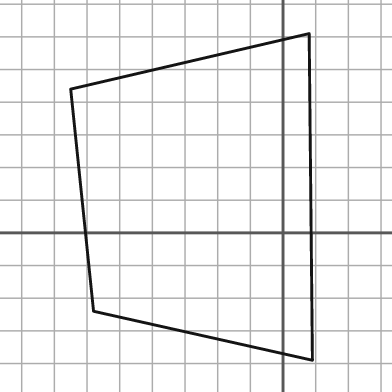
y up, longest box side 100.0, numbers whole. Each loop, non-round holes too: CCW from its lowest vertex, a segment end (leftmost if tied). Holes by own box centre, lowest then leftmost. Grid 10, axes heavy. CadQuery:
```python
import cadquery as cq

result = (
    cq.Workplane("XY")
    .moveTo(9.0, -39.0)
    .lineTo(8.0, 61.0)
    .lineTo(-65.0, 44.0)
    .lineTo(-58.0, -24.0)
    .close()
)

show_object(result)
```